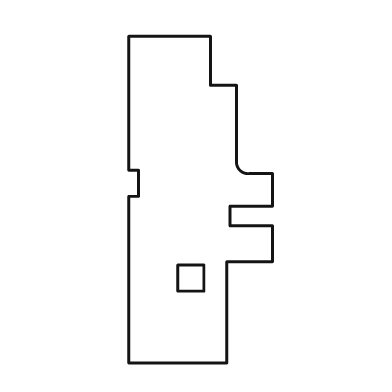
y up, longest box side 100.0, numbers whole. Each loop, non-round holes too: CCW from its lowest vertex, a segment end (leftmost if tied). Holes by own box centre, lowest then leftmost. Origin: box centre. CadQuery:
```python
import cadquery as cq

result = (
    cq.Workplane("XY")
    .moveTo(-22.0, -50.0)
    .lineTo(8.0, -50.0)
    .lineTo(8.0, -19.0)
    .lineTo(22.0, -19.0)
    .lineTo(22.0, -8.0)
    .lineTo(9.0, -8.0)
    .lineTo(9.0, -2.0)
    .lineTo(22.0, -2.0)
    .lineTo(22.0, 8.0)
    .lineTo(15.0, 8.0)
    .threePointArc((12.0, 9.0), (11.0, 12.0))
    .lineTo(11.0, 35.0)
    .lineTo(3.0, 35.0)
    .lineTo(3.0, 50.0)
    .lineTo(-22.0, 50.0)
    .lineTo(-22.0, 9.0)
    .lineTo(-19.0, 9.0)
    .lineTo(-19.0, 1.0)
    .lineTo(-22.0, 1.0)
    .close()
    .moveTo(-7.0, -28.0)
    .lineTo(1.0, -28.0)
    .lineTo(1.0, -20.0)
    .lineTo(-7.0, -20.0)
    .close()
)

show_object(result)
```